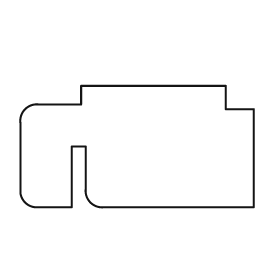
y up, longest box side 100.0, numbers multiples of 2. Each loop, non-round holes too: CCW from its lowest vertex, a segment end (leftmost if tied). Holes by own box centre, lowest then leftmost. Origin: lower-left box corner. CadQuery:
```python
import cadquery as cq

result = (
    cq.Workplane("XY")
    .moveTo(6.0, 0.0)
    .lineTo(22.0, 0.0)
    .lineTo(22.0, 26.0)
    .lineTo(28.0, 26.0)
    .lineTo(28.0, 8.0)
    .threePointArc((30.0, 2.0), (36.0, 0.0))
    .lineTo(100.0, 0.0)
    .lineTo(100.0, 42.0)
    .lineTo(88.0, 42.0)
    .lineTo(88.0, 52.0)
    .lineTo(26.0, 52.0)
    .lineTo(26.0, 44.0)
    .lineTo(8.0, 44.0)
    .threePointArc((2.0, 42.0), (0.0, 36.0))
    .lineTo(0.0, 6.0)
    .threePointArc((2.0, 2.0), (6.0, 0.0))
    .close()
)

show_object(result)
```